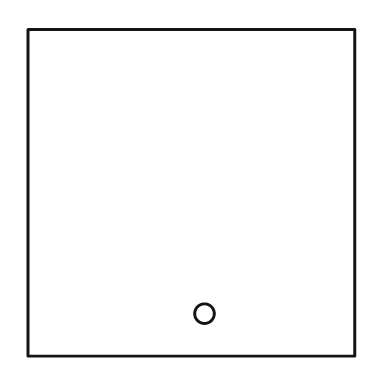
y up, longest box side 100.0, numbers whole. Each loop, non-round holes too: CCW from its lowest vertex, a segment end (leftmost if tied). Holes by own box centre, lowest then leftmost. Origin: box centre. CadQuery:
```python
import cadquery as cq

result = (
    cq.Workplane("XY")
    .moveTo(-50.0, -50.0)
    .lineTo(50.0, -50.0)
    .lineTo(50.0, 50.0)
    .lineTo(-50.0, 50.0)
    .close()
    .moveTo(4.0, -37.0)
    .circle(3.0)
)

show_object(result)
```